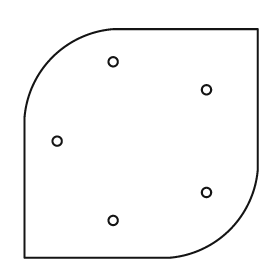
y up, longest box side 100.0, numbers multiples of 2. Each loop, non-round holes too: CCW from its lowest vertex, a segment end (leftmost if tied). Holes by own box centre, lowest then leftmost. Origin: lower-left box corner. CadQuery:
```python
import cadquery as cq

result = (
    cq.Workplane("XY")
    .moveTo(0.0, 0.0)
    .lineTo(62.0, 0.0)
    .threePointArc((88.0, 12.0), (100.0, 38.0))
    .lineTo(100.0, 98.0)
    .lineTo(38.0, 98.0)
    .threePointArc((12.0, 86.0), (0.0, 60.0))
    .close()
    .moveTo(38.0, 16.0)
    .circle(2.0)
    .moveTo(78.0, 28.0)
    .circle(2.0)
    .moveTo(14.0, 50.0)
    .circle(2.0)
    .moveTo(78.0, 72.0)
    .circle(2.0)
    .moveTo(38.0, 84.0)
    .circle(2.0)
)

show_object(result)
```